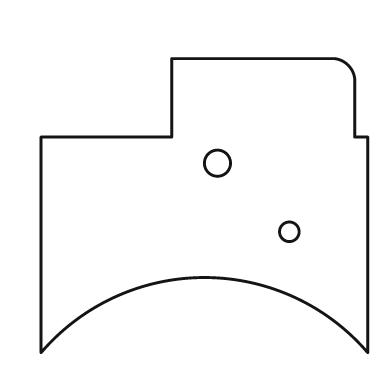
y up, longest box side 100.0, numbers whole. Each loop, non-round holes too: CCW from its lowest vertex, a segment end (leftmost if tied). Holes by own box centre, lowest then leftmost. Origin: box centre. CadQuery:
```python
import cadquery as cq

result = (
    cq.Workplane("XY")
    .moveTo(-50.0, -45.0)
    .threePointArc((0.0, -22.0), (50.0, -45.0))
    .lineTo(50.0, 21.0)
    .lineTo(46.0, 21.0)
    .lineTo(46.0, 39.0)
    .threePointArc((44.0, 43.0), (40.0, 45.0))
    .lineTo(-10.0, 45.0)
    .lineTo(-10.0, 21.0)
    .lineTo(-50.0, 21.0)
    .close()
    .moveTo(26.0, -8.0)
    .circle(3.0)
    .moveTo(4.0, 13.0)
    .circle(4.0)
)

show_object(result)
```